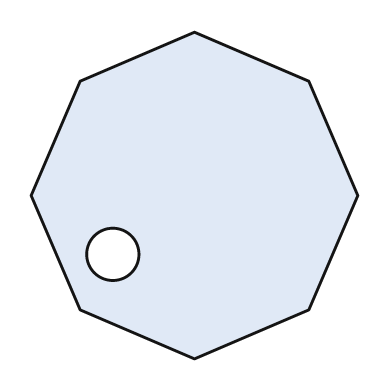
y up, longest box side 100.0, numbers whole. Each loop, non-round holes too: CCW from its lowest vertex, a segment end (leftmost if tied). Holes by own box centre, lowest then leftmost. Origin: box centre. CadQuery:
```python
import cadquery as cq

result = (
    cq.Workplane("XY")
    .moveTo(0.0, -50.0)
    .lineTo(35.0, -35.0)
    .lineTo(50.0, 0.0)
    .lineTo(35.0, 35.0)
    .lineTo(0.0, 50.0)
    .lineTo(-35.0, 35.0)
    .lineTo(-50.0, 0.0)
    .lineTo(-35.0, -35.0)
    .close()
    .moveTo(-25.0, -18.0)
    .circle(8.0)
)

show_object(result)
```